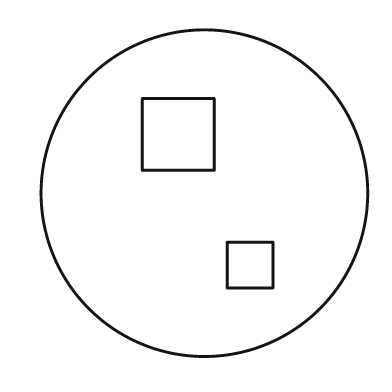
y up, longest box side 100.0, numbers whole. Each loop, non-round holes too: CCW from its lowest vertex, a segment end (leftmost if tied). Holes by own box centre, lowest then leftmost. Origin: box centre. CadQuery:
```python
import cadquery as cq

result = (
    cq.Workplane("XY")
    .moveTo(0.0, 0.0)
    .circle(50.0)
    .moveTo(7.0, -29.0)
    .lineTo(21.0, -29.0)
    .lineTo(21.0, -15.0)
    .lineTo(7.0, -15.0)
    .close()
    .moveTo(-19.0, 7.0)
    .lineTo(3.0, 7.0)
    .lineTo(3.0, 29.0)
    .lineTo(-19.0, 29.0)
    .close()
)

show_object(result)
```